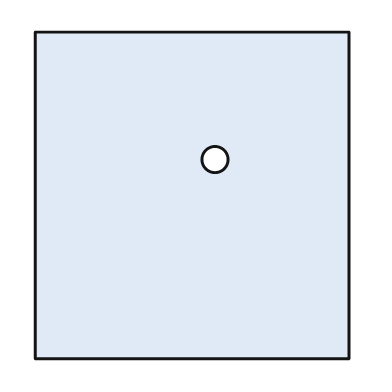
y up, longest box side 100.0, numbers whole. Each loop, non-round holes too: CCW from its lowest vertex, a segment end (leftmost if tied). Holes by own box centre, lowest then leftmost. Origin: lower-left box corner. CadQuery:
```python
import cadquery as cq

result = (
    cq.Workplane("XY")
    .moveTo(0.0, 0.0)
    .lineTo(96.0, 0.0)
    .lineTo(96.0, 100.0)
    .lineTo(0.0, 100.0)
    .close()
    .moveTo(55.0, 61.0)
    .circle(4.0)
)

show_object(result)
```